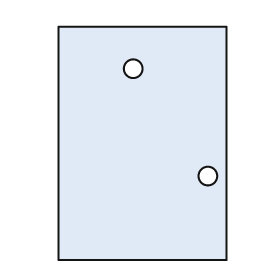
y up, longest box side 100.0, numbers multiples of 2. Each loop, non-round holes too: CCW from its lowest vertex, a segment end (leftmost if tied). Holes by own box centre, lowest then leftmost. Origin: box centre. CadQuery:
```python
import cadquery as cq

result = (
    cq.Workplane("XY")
    .moveTo(-36.0, -50.0)
    .lineTo(36.0, -50.0)
    .lineTo(36.0, 50.0)
    .lineTo(-36.0, 50.0)
    .close()
    .moveTo(28.0, -14.0)
    .circle(4.0)
    .moveTo(-4.0, 32.0)
    .circle(4.0)
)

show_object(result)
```